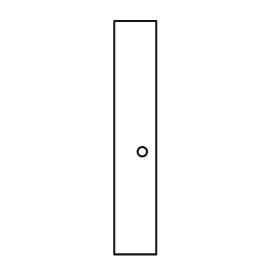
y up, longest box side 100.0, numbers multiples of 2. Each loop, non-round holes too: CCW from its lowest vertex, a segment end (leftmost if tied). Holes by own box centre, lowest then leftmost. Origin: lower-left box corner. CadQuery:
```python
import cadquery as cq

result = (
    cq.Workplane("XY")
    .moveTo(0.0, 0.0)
    .lineTo(18.0, 0.0)
    .lineTo(18.0, 100.0)
    .lineTo(0.0, 100.0)
    .close()
    .moveTo(12.0, 44.0)
    .circle(2.0)
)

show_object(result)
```